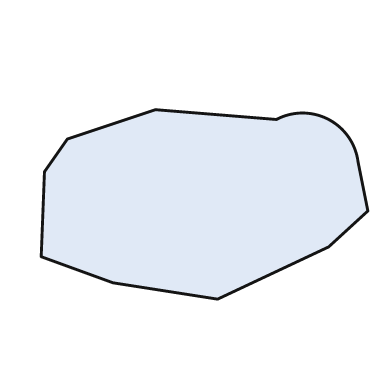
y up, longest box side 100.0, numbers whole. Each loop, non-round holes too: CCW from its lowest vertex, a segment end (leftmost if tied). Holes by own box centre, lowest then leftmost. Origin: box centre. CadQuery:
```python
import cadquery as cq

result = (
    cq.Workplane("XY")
    .moveTo(4.0, -29.0)
    .lineTo(38.0, -13.0)
    .lineTo(50.0, -2.0)
    .lineTo(47.0, 13.0)
    .threePointArc((38.0, 26.0), (22.0, 26.0))
    .lineTo(-15.0, 29.0)
    .lineTo(-42.0, 20.0)
    .lineTo(-49.0, 10.0)
    .lineTo(-50.0, -16.0)
    .lineTo(-28.0, -24.0)
    .close()
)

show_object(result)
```